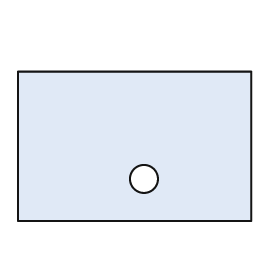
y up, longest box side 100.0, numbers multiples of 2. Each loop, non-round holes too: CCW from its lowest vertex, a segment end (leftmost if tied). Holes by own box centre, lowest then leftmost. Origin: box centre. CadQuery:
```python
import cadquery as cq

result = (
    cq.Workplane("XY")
    .moveTo(-50.0, -32.0)
    .lineTo(50.0, -32.0)
    .lineTo(50.0, 32.0)
    .lineTo(-50.0, 32.0)
    .close()
    .moveTo(4.0, -14.0)
    .circle(6.0)
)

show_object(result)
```